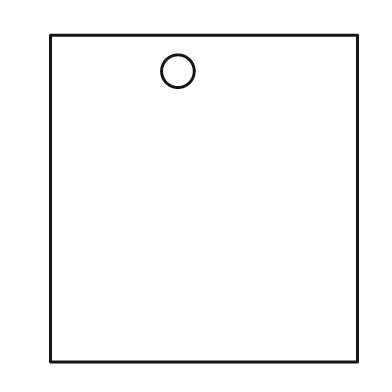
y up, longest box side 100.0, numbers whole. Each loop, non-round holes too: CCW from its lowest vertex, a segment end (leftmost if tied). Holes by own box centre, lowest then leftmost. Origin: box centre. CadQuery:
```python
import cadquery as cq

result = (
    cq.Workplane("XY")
    .moveTo(-47.0, -50.0)
    .lineTo(47.0, -50.0)
    .lineTo(47.0, 50.0)
    .lineTo(-47.0, 50.0)
    .close()
    .moveTo(-8.0, 39.0)
    .circle(5.0)
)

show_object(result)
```